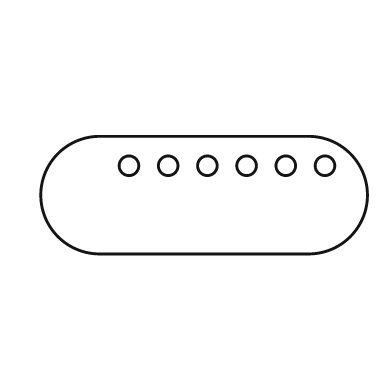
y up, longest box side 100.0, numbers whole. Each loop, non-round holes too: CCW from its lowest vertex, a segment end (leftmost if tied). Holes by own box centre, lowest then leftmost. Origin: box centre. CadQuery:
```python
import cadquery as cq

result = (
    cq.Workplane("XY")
    .moveTo(-32.0, -18.0)
    .lineTo(32.0, -18.0)
    .threePointArc((50.0, 0.0), (32.0, 18.0))
    .lineTo(-32.0, 18.0)
    .threePointArc((-50.0, 0.0), (-32.0, -18.0))
    .close()
    .moveTo(-23.0, 9.0)
    .circle(3.0)
    .moveTo(-11.0, 9.0)
    .circle(3.0)
    .moveTo(1.0, 9.0)
    .circle(3.0)
    .moveTo(13.0, 9.0)
    .circle(3.0)
    .moveTo(25.0, 9.0)
    .circle(3.0)
    .moveTo(37.0, 9.0)
    .circle(3.0)
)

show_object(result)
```